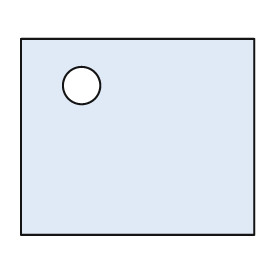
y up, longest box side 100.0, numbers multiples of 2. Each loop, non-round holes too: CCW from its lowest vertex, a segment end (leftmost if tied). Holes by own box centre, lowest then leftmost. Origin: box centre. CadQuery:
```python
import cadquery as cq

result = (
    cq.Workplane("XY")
    .moveTo(-50.0, -42.0)
    .lineTo(50.0, -42.0)
    .lineTo(50.0, 42.0)
    .lineTo(-50.0, 42.0)
    .close()
    .moveTo(-24.0, 22.0)
    .circle(8.0)
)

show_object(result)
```